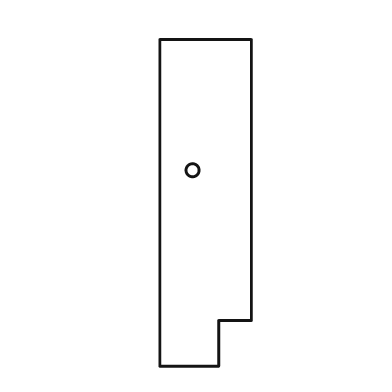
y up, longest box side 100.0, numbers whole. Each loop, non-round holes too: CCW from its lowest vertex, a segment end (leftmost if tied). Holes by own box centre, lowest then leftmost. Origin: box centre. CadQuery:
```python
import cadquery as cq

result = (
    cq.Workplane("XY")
    .moveTo(-14.0, -50.0)
    .lineTo(4.0, -50.0)
    .lineTo(4.0, -36.0)
    .lineTo(14.0, -36.0)
    .lineTo(14.0, 50.0)
    .lineTo(-14.0, 50.0)
    .close()
    .moveTo(-4.0, 10.0)
    .circle(2.0)
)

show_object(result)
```